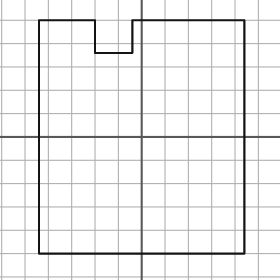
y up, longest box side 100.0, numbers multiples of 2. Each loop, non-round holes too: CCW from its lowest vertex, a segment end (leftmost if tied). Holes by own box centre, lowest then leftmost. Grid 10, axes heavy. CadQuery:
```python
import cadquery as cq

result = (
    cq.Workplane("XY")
    .moveTo(-44.0, -50.0)
    .lineTo(44.0, -50.0)
    .lineTo(44.0, 50.0)
    .lineTo(-4.0, 50.0)
    .lineTo(-4.0, 36.0)
    .lineTo(-20.0, 36.0)
    .lineTo(-20.0, 50.0)
    .lineTo(-44.0, 50.0)
    .close()
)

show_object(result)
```